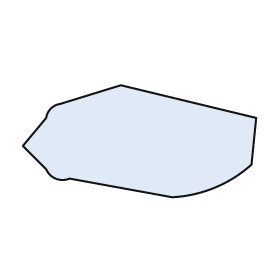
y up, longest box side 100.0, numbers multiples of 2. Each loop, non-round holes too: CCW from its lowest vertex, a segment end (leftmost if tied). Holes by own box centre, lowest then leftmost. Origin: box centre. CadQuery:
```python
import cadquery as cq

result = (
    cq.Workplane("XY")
    .moveTo(14.0, -24.0)
    .threePointArc((32.0, -20.0), (48.0, -10.0))
    .lineTo(50.0, 10.0)
    .lineTo(-8.0, 24.0)
    .lineTo(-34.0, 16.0)
    .threePointArc((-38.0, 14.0), (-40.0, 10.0))
    .lineTo(-50.0, -2.0)
    .lineTo(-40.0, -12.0)
    .threePointArc((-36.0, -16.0), (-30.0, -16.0))
    .close()
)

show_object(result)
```